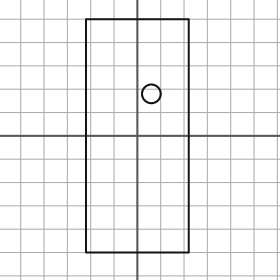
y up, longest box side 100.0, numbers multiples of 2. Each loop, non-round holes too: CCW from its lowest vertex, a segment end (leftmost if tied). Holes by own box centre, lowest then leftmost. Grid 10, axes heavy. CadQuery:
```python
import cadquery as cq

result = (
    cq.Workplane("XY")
    .moveTo(-22.0, -50.0)
    .lineTo(22.0, -50.0)
    .lineTo(22.0, 50.0)
    .lineTo(-22.0, 50.0)
    .close()
    .moveTo(6.0, 18.0)
    .circle(4.0)
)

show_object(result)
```